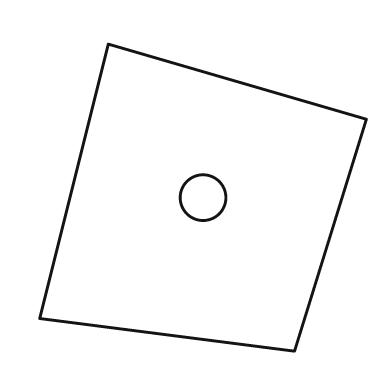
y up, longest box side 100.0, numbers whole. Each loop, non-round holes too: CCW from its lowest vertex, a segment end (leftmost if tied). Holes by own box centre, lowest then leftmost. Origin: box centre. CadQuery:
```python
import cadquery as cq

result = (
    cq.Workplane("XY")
    .moveTo(28.0, -47.0)
    .lineTo(50.0, 24.0)
    .lineTo(-29.0, 47.0)
    .lineTo(-50.0, -37.0)
    .close()
    .moveTo(0.0, 0.0)
    .circle(7.0)
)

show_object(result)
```